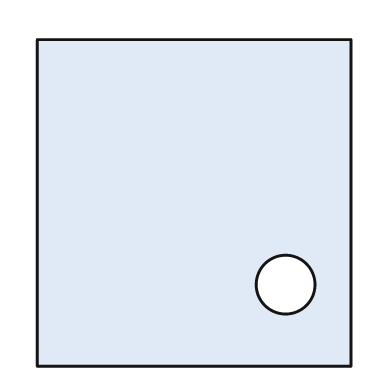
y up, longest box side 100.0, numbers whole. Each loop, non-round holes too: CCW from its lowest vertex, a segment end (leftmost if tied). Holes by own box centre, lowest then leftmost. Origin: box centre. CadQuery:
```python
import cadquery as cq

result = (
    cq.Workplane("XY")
    .moveTo(-48.0, -50.0)
    .lineTo(48.0, -50.0)
    .lineTo(48.0, 50.0)
    .lineTo(-48.0, 50.0)
    .close()
    .moveTo(28.0, -25.0)
    .circle(9.0)
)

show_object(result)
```